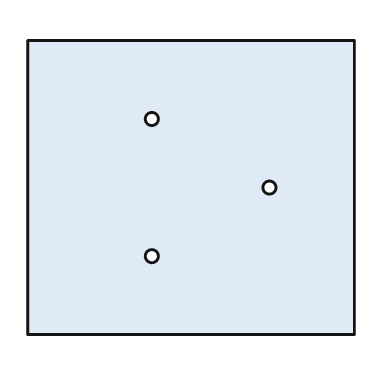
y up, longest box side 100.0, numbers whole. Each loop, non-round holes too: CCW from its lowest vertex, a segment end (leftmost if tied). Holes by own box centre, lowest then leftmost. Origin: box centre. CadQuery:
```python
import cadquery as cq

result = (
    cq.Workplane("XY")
    .moveTo(-50.0, -45.0)
    .lineTo(50.0, -45.0)
    .lineTo(50.0, 45.0)
    .lineTo(-50.0, 45.0)
    .close()
    .moveTo(-12.0, -21.0)
    .circle(2.0)
    .moveTo(24.0, 0.0)
    .circle(2.0)
    .moveTo(-12.0, 21.0)
    .circle(2.0)
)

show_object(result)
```